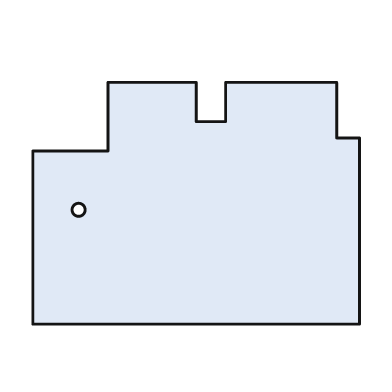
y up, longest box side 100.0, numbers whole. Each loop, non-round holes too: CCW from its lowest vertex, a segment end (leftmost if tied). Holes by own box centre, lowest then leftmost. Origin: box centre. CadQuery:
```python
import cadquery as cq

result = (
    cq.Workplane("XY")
    .moveTo(-50.0, -37.0)
    .lineTo(50.0, -37.0)
    .lineTo(50.0, 20.0)
    .lineTo(43.0, 20.0)
    .lineTo(43.0, 37.0)
    .lineTo(9.0, 37.0)
    .lineTo(9.0, 25.0)
    .lineTo(0.0, 25.0)
    .lineTo(0.0, 37.0)
    .lineTo(-27.0, 37.0)
    .lineTo(-27.0, 16.0)
    .lineTo(-50.0, 16.0)
    .close()
    .moveTo(-36.0, -2.0)
    .circle(2.0)
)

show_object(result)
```